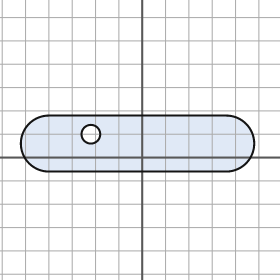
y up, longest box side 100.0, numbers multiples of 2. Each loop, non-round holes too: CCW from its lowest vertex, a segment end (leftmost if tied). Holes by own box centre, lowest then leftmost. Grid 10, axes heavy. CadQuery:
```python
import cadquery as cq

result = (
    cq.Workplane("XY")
    .moveTo(-40.0, -6.0)
    .lineTo(36.0, -6.0)
    .threePointArc((48.0, 6.0), (36.0, 18.0))
    .lineTo(-40.0, 18.0)
    .threePointArc((-52.0, 6.0), (-40.0, -6.0))
    .close()
    .moveTo(-22.0, 10.0)
    .circle(4.0)
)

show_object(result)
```